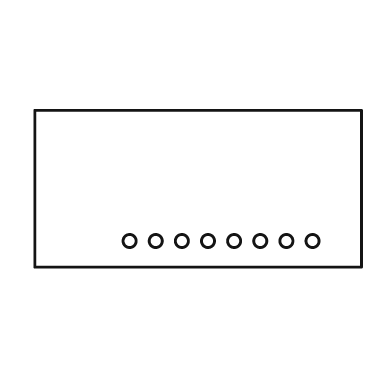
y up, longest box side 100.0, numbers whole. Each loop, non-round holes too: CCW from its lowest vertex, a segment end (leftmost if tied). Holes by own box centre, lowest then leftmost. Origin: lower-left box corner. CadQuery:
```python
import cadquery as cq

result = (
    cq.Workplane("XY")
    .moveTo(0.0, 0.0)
    .lineTo(100.0, 0.0)
    .lineTo(100.0, 48.0)
    .lineTo(0.0, 48.0)
    .close()
    .moveTo(29.0, 8.0)
    .circle(2.0)
    .moveTo(37.0, 8.0)
    .circle(2.0)
    .moveTo(45.0, 8.0)
    .circle(2.0)
    .moveTo(53.0, 8.0)
    .circle(2.0)
    .moveTo(61.0, 8.0)
    .circle(2.0)
    .moveTo(69.0, 8.0)
    .circle(2.0)
    .moveTo(77.0, 8.0)
    .circle(2.0)
    .moveTo(85.0, 8.0)
    .circle(2.0)
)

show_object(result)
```